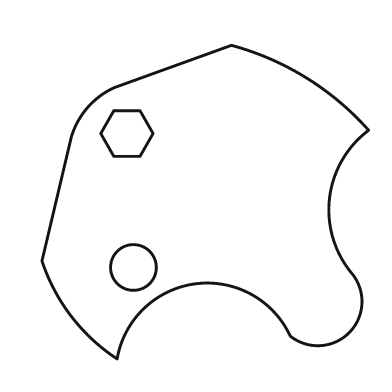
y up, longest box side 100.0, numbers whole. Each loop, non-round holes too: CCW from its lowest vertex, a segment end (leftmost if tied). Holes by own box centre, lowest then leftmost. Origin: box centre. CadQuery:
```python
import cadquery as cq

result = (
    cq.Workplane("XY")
    .moveTo(-27.0, -48.0)
    .threePointArc((-3.0, -25.0), (26.0, -41.0))
    .threePointArc((44.0, -40.0), (45.0, -22.0))
    .threePointArc((38.0, 1.0), (50.0, 22.0))
    .threePointArc((31.0, 38.0), (8.0, 48.0))
    .lineTo(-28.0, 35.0)
    .threePointArc((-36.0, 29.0), (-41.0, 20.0))
    .lineTo(-50.0, -18.0)
    .threePointArc((-41.0, -35.0), (-27.0, -48.0))
    .close()
    .moveTo(-22.0, -20.0)
    .circle(7.0)
    .moveTo(-28.0, 14.0)
    .lineTo(-20.0, 14.0)
    .lineTo(-16.0, 21.0)
    .lineTo(-20.0, 28.0)
    .lineTo(-28.0, 28.0)
    .lineTo(-32.0, 21.0)
    .close()
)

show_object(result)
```